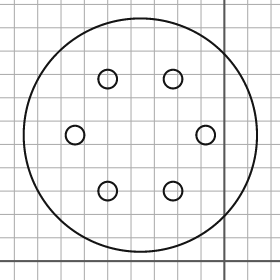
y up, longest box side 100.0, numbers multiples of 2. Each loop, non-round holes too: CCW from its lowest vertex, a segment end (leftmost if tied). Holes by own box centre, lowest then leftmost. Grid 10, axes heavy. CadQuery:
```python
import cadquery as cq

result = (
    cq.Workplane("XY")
    .moveTo(-36.0, 54.0)
    .circle(50.0)
    .moveTo(-50.0, 30.0)
    .circle(4.0)
    .moveTo(-22.0, 30.0)
    .circle(4.0)
    .moveTo(-64.0, 54.0)
    .circle(4.0)
    .moveTo(-8.0, 54.0)
    .circle(4.0)
    .moveTo(-50.0, 78.0)
    .circle(4.0)
    .moveTo(-22.0, 78.0)
    .circle(4.0)
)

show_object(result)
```